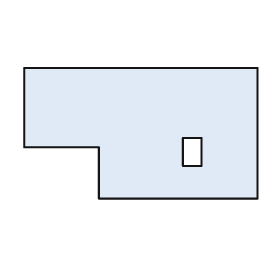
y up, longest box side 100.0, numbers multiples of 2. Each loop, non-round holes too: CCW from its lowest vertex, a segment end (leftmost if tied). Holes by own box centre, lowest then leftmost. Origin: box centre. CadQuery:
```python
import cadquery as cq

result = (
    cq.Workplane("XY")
    .moveTo(-18.0, -28.0)
    .lineTo(50.0, -28.0)
    .lineTo(50.0, 28.0)
    .lineTo(-50.0, 28.0)
    .lineTo(-50.0, -6.0)
    .lineTo(-18.0, -6.0)
    .close()
    .moveTo(18.0, -14.0)
    .lineTo(26.0, -14.0)
    .lineTo(26.0, -2.0)
    .lineTo(18.0, -2.0)
    .close()
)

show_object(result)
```